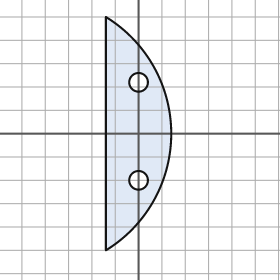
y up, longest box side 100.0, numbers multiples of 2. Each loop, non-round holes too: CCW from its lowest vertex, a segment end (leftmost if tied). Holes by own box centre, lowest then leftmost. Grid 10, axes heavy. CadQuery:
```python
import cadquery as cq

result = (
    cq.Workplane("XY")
    .moveTo(-14.0, -50.0)
    .threePointArc((14.0, 0.0), (-14.0, 50.0))
    .close()
    .moveTo(0.0, -20.0)
    .circle(4.0)
    .moveTo(0.0, 22.0)
    .circle(4.0)
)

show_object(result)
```